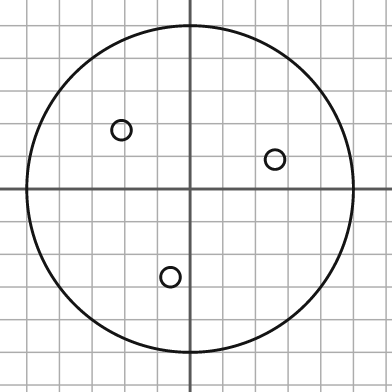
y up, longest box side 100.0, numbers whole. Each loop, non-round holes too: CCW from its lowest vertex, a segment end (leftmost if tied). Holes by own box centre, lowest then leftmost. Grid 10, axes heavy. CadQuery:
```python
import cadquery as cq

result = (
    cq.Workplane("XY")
    .moveTo(0.0, 0.0)
    .circle(50.0)
    .moveTo(-6.0, -27.0)
    .circle(3.0)
    .moveTo(26.0, 9.0)
    .circle(3.0)
    .moveTo(-21.0, 18.0)
    .circle(3.0)
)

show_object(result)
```